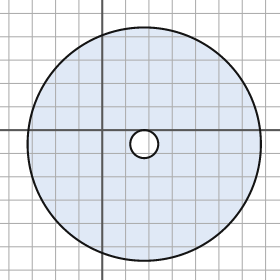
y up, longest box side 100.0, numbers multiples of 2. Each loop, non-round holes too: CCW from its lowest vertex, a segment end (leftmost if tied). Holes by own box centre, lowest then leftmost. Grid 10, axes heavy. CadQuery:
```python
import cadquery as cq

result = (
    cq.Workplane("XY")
    .moveTo(18.0, -6.0)
    .circle(50.0)
    .moveTo(18.0, -6.0)
    .circle(6.0)
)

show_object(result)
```